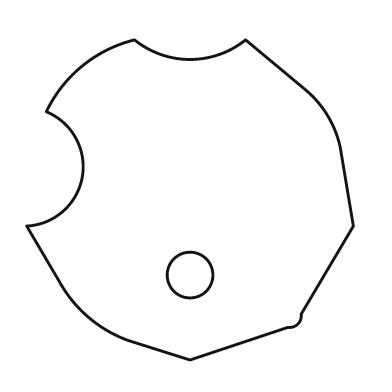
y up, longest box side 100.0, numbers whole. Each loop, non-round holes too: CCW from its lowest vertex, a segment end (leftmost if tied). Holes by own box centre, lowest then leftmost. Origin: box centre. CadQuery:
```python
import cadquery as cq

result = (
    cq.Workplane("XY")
    .moveTo(0.0, -49.0)
    .lineTo(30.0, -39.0)
    .threePointArc((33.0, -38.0), (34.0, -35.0))
    .lineTo(50.0, -8.0)
    .lineTo(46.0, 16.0)
    .threePointArc((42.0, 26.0), (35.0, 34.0))
    .lineTo(17.0, 49.0)
    .threePointArc((0.0, 43.0), (-17.0, 49.0))
    .threePointArc((-33.0, 41.0), (-44.0, 27.0))
    .threePointArc((-33.0, 7.0), (-50.0, -8.0))
    .lineTo(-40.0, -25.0)
    .threePointArc((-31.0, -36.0), (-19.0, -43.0))
    .close()
    .moveTo(0.0, -23.0)
    .circle(7.0)
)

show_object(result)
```